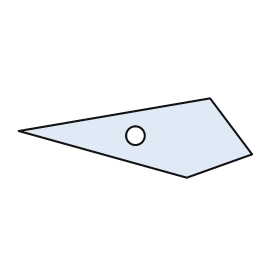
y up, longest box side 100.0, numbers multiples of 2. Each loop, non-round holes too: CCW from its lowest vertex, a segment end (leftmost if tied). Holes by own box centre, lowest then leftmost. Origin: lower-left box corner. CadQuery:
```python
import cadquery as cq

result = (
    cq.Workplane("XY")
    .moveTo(72.0, 0.0)
    .lineTo(100.0, 10.0)
    .lineTo(82.0, 34.0)
    .lineTo(0.0, 20.0)
    .close()
    .moveTo(50.0, 18.0)
    .circle(4.0)
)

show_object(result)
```